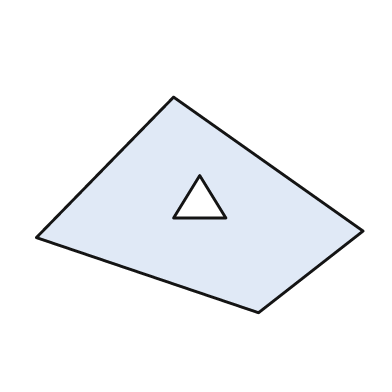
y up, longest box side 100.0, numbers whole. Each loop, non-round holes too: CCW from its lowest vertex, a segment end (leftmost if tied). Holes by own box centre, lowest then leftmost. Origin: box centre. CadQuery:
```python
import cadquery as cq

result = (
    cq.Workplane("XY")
    .moveTo(18.0, -33.0)
    .lineTo(50.0, -8.0)
    .lineTo(-8.0, 33.0)
    .lineTo(-50.0, -10.0)
    .close()
    .moveTo(-8.0, -4.0)
    .lineTo(8.0, -4.0)
    .lineTo(0.0, 9.0)
    .close()
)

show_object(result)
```